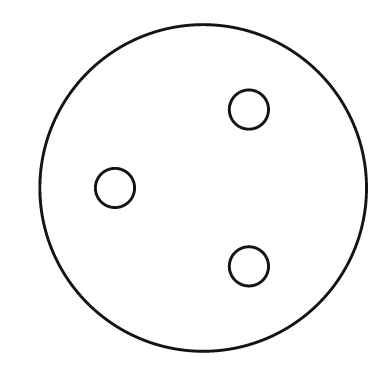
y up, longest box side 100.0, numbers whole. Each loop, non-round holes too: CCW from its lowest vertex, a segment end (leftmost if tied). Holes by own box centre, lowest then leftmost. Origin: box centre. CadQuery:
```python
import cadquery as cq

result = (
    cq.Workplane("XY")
    .moveTo(0.0, 0.0)
    .circle(50.0)
    .moveTo(14.0, -24.0)
    .circle(6.0)
    .moveTo(-27.0, 0.0)
    .circle(6.0)
    .moveTo(14.0, 24.0)
    .circle(6.0)
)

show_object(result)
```